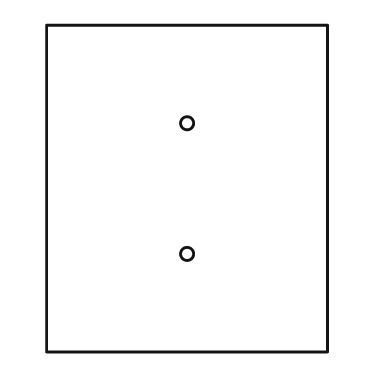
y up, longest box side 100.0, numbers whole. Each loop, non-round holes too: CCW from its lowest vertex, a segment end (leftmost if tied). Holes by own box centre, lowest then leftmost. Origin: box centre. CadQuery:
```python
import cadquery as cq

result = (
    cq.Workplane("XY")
    .moveTo(-43.0, -50.0)
    .lineTo(43.0, -50.0)
    .lineTo(43.0, 50.0)
    .lineTo(-43.0, 50.0)
    .close()
    .moveTo(0.0, -20.0)
    .circle(2.0)
    .moveTo(0.0, 20.0)
    .circle(2.0)
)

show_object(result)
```